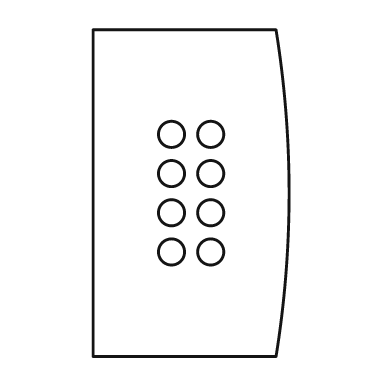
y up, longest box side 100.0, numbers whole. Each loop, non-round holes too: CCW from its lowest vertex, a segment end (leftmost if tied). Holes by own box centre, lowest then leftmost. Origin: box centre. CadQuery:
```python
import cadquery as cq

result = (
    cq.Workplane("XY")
    .moveTo(-30.0, -50.0)
    .lineTo(26.0, -50.0)
    .threePointArc((30.0, 0.0), (26.0, 50.0))
    .lineTo(-30.0, 50.0)
    .close()
    .moveTo(-6.0, -18.0)
    .circle(4.0)
    .moveTo(6.0, -18.0)
    .circle(4.0)
    .moveTo(-6.0, -6.0)
    .circle(4.0)
    .moveTo(6.0, -6.0)
    .circle(4.0)
    .moveTo(-6.0, 6.0)
    .circle(4.0)
    .moveTo(6.0, 6.0)
    .circle(4.0)
    .moveTo(-6.0, 18.0)
    .circle(4.0)
    .moveTo(6.0, 18.0)
    .circle(4.0)
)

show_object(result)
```